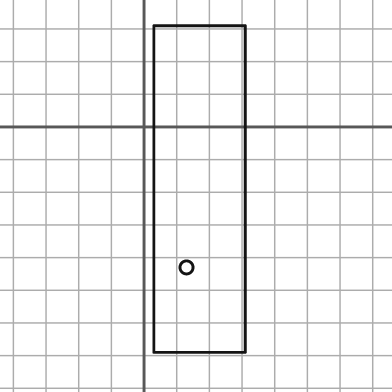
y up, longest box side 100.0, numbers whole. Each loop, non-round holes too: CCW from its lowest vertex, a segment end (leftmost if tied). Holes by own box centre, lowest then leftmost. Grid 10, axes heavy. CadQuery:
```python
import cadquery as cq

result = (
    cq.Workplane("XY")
    .moveTo(3.0, -69.0)
    .lineTo(31.0, -69.0)
    .lineTo(31.0, 31.0)
    .lineTo(3.0, 31.0)
    .close()
    .moveTo(13.0, -43.0)
    .circle(2.0)
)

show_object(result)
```